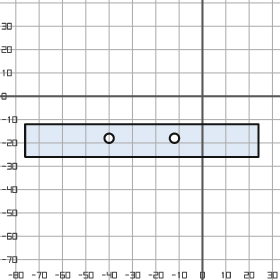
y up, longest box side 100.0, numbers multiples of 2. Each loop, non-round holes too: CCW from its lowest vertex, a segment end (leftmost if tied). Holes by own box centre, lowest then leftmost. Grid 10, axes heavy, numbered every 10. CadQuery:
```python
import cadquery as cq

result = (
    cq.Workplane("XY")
    .moveTo(-76.0, -26.0)
    .lineTo(24.0, -26.0)
    .lineTo(24.0, -12.0)
    .lineTo(-76.0, -12.0)
    .close()
    .moveTo(-40.0, -18.0)
    .circle(2.0)
    .moveTo(-12.0, -18.0)
    .circle(2.0)
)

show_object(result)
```